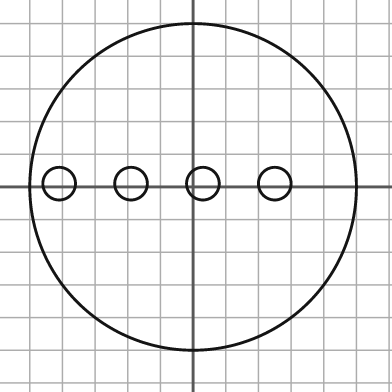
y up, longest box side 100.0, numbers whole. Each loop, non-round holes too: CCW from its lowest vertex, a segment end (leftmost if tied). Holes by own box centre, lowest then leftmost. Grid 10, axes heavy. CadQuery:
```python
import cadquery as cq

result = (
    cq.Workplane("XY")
    .moveTo(0.0, 0.0)
    .circle(50.0)
    .moveTo(-41.0, 1.0)
    .circle(5.0)
    .moveTo(-19.0, 1.0)
    .circle(5.0)
    .moveTo(3.0, 1.0)
    .circle(5.0)
    .moveTo(25.0, 1.0)
    .circle(5.0)
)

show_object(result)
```